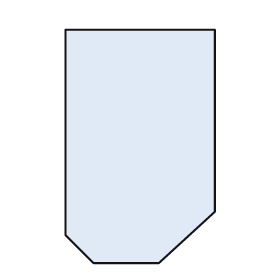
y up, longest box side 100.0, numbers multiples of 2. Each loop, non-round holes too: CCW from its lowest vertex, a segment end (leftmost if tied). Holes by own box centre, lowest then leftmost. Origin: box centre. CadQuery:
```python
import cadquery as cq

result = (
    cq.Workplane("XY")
    .moveTo(-20.0, -50.0)
    .lineTo(8.0, -50.0)
    .lineTo(32.0, -28.0)
    .lineTo(32.0, 50.0)
    .lineTo(-32.0, 50.0)
    .lineTo(-32.0, -38.0)
    .close()
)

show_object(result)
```